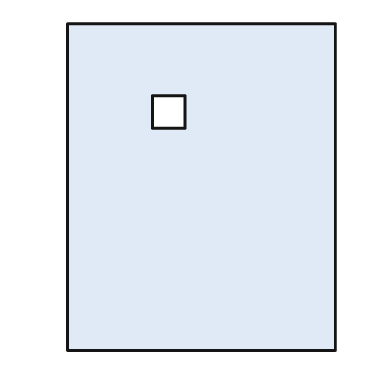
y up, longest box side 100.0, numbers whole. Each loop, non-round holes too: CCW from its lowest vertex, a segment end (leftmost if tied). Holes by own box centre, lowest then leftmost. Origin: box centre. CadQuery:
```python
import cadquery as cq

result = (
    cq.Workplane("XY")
    .moveTo(-41.0, -50.0)
    .lineTo(41.0, -50.0)
    .lineTo(41.0, 50.0)
    .lineTo(-41.0, 50.0)
    .close()
    .moveTo(-15.0, 18.0)
    .lineTo(-5.0, 18.0)
    .lineTo(-5.0, 28.0)
    .lineTo(-15.0, 28.0)
    .close()
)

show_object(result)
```